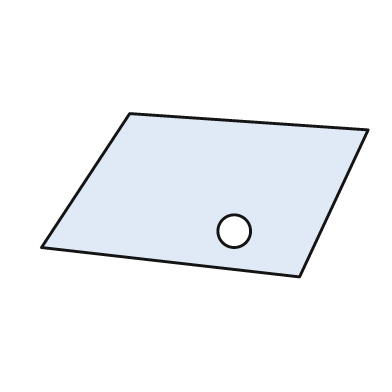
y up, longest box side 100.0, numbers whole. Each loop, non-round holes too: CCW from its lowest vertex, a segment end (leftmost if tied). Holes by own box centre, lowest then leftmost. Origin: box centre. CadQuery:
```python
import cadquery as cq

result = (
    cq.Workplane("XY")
    .moveTo(29.0, -25.0)
    .lineTo(50.0, 20.0)
    .lineTo(-23.0, 25.0)
    .lineTo(-50.0, -16.0)
    .close()
    .moveTo(9.0, -11.0)
    .circle(5.0)
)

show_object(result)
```